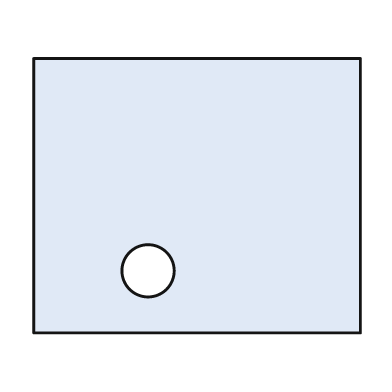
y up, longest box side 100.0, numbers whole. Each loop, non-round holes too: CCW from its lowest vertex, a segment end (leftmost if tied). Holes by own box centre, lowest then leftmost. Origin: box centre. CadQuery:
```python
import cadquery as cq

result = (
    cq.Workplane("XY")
    .moveTo(-50.0, -42.0)
    .lineTo(50.0, -42.0)
    .lineTo(50.0, 42.0)
    .lineTo(-50.0, 42.0)
    .close()
    .moveTo(-15.0, -23.0)
    .circle(8.0)
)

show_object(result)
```